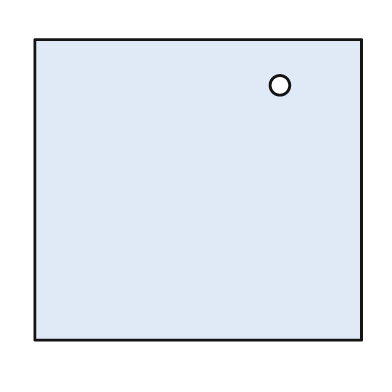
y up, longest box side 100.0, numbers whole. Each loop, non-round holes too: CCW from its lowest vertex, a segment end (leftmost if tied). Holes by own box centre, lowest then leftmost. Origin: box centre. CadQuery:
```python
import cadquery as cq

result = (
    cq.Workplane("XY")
    .moveTo(-50.0, -46.0)
    .lineTo(50.0, -46.0)
    .lineTo(50.0, 46.0)
    .lineTo(-50.0, 46.0)
    .close()
    .moveTo(25.0, 32.0)
    .circle(3.0)
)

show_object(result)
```